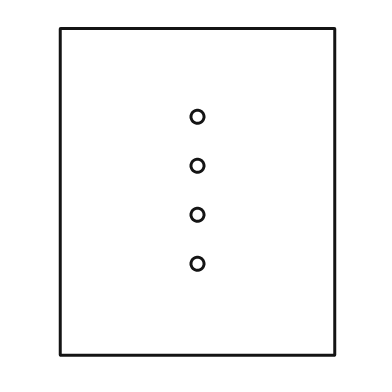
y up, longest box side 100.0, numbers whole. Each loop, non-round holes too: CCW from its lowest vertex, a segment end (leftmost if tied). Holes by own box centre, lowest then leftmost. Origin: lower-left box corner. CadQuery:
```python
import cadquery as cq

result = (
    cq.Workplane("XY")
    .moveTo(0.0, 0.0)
    .lineTo(84.0, 0.0)
    .lineTo(84.0, 100.0)
    .lineTo(0.0, 100.0)
    .close()
    .moveTo(42.0, 28.0)
    .circle(2.0)
    .moveTo(42.0, 43.0)
    .circle(2.0)
    .moveTo(42.0, 58.0)
    .circle(2.0)
    .moveTo(42.0, 73.0)
    .circle(2.0)
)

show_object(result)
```